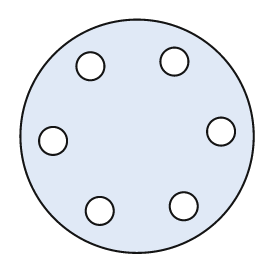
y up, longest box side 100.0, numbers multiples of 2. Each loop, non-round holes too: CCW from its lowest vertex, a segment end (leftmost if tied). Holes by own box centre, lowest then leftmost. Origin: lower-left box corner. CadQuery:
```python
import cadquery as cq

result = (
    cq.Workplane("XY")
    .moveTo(50.0, 50.0)
    .circle(50.0)
    .moveTo(34.0, 18.0)
    .circle(6.0)
    .moveTo(70.0, 20.0)
    .circle(6.0)
    .moveTo(14.0, 48.0)
    .circle(6.0)
    .moveTo(86.0, 52.0)
    .circle(6.0)
    .moveTo(30.0, 80.0)
    .circle(6.0)
    .moveTo(66.0, 82.0)
    .circle(6.0)
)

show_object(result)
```